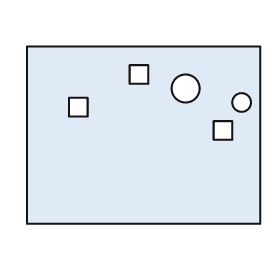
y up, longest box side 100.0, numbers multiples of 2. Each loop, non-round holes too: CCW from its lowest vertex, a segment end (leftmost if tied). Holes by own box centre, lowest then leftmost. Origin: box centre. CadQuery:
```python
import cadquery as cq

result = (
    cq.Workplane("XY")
    .moveTo(-50.0, -38.0)
    .lineTo(50.0, -38.0)
    .lineTo(50.0, 38.0)
    .lineTo(-50.0, 38.0)
    .close()
    .moveTo(30.0, -2.0)
    .lineTo(38.0, -2.0)
    .lineTo(38.0, 6.0)
    .lineTo(30.0, 6.0)
    .close()
    .moveTo(-32.0, 8.0)
    .lineTo(-24.0, 8.0)
    .lineTo(-24.0, 16.0)
    .lineTo(-32.0, 16.0)
    .close()
    .moveTo(42.0, 14.0)
    .circle(4.0)
    .moveTo(18.0, 20.0)
    .circle(6.0)
    .moveTo(-6.0, 22.0)
    .lineTo(2.0, 22.0)
    .lineTo(2.0, 30.0)
    .lineTo(-6.0, 30.0)
    .close()
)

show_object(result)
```